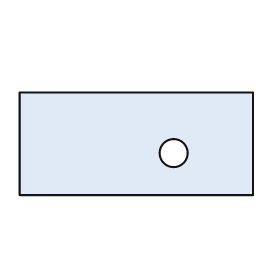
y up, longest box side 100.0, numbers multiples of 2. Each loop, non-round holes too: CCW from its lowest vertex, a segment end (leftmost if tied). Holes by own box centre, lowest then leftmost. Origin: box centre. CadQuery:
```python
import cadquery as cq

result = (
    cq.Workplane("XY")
    .moveTo(-50.0, -22.0)
    .lineTo(50.0, -22.0)
    .lineTo(50.0, 22.0)
    .lineTo(-50.0, 22.0)
    .close()
    .moveTo(16.0, -4.0)
    .circle(6.0)
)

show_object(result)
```